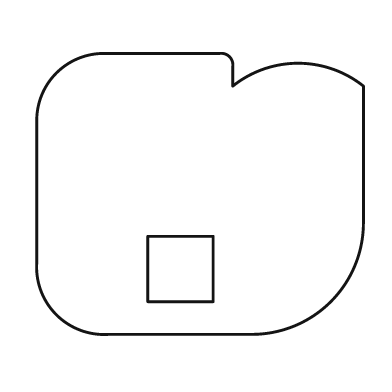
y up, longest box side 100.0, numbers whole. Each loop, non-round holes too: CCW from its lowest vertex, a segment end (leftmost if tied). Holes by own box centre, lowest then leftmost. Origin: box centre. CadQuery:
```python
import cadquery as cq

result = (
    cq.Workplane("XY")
    .moveTo(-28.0, -43.0)
    .lineTo(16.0, -43.0)
    .threePointArc((40.0, -33.0), (50.0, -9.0))
    .lineTo(50.0, 33.0)
    .threePointArc((30.0, 40.0), (10.0, 33.0))
    .lineTo(10.0, 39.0)
    .threePointArc((9.0, 42.0), (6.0, 43.0))
    .lineTo(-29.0, 43.0)
    .threePointArc((-44.0, 37.0), (-50.0, 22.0))
    .lineTo(-50.0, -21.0)
    .threePointArc((-44.0, -37.0), (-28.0, -43.0))
    .close()
    .moveTo(-16.0, -33.0)
    .lineTo(4.0, -33.0)
    .lineTo(4.0, -13.0)
    .lineTo(-16.0, -13.0)
    .close()
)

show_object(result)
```